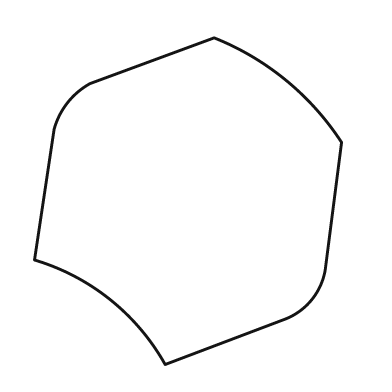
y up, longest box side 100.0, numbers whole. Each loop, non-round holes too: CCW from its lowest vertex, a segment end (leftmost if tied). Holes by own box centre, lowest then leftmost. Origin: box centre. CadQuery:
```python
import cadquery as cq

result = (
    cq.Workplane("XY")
    .moveTo(-7.0, -50.0)
    .lineTo(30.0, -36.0)
    .threePointArc((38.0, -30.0), (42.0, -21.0))
    .lineTo(47.0, 18.0)
    .threePointArc((30.0, 37.0), (8.0, 50.0))
    .lineTo(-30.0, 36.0)
    .threePointArc((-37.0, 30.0), (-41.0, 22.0))
    .lineTo(-47.0, -18.0)
    .threePointArc((-24.0, -30.0), (-7.0, -50.0))
    .close()
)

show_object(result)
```